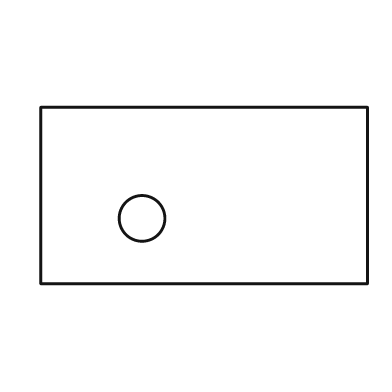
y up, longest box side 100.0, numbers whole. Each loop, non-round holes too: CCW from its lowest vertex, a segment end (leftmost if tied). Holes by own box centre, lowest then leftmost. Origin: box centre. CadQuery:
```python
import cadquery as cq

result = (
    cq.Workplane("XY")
    .moveTo(-50.0, -27.0)
    .lineTo(50.0, -27.0)
    .lineTo(50.0, 27.0)
    .lineTo(-50.0, 27.0)
    .close()
    .moveTo(-19.0, -7.0)
    .circle(7.0)
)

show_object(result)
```